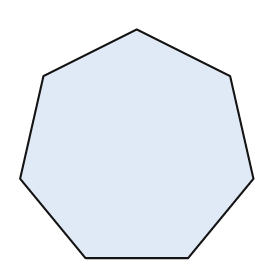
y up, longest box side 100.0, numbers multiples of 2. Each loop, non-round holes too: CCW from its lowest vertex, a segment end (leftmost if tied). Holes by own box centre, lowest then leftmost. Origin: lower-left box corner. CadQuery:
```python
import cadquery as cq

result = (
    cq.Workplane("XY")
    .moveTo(28.0, 0.0)
    .lineTo(72.0, 0.0)
    .lineTo(100.0, 34.0)
    .lineTo(90.0, 78.0)
    .lineTo(50.0, 98.0)
    .lineTo(10.0, 78.0)
    .lineTo(0.0, 34.0)
    .close()
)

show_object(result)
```